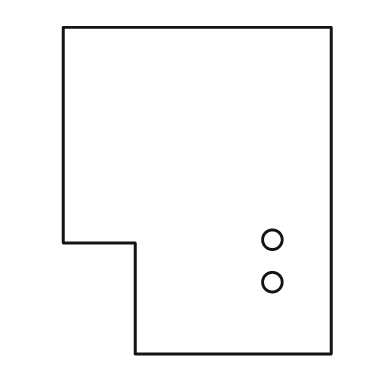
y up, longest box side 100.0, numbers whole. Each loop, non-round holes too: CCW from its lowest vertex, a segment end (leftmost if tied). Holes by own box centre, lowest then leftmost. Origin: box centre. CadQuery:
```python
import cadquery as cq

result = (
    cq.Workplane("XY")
    .moveTo(-19.0, -50.0)
    .lineTo(41.0, -50.0)
    .lineTo(41.0, 50.0)
    .lineTo(-41.0, 50.0)
    .lineTo(-41.0, -16.0)
    .lineTo(-19.0, -16.0)
    .close()
    .moveTo(23.0, -28.0)
    .circle(3.0)
    .moveTo(23.0, -15.0)
    .circle(3.0)
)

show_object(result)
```